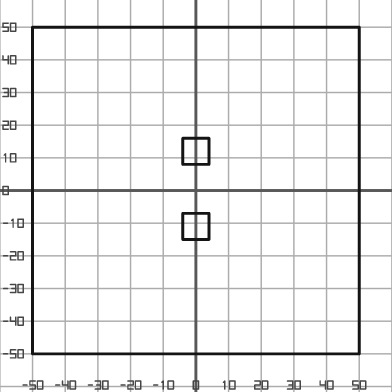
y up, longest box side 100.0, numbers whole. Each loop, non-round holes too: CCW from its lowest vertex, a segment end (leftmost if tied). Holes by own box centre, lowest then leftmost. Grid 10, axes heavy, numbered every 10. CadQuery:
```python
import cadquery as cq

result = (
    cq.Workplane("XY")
    .moveTo(-50.0, -50.0)
    .lineTo(50.0, -50.0)
    .lineTo(50.0, 50.0)
    .lineTo(-50.0, 50.0)
    .close()
    .moveTo(-4.0, -15.0)
    .lineTo(4.0, -15.0)
    .lineTo(4.0, -7.0)
    .lineTo(-4.0, -7.0)
    .close()
    .moveTo(-4.0, 8.0)
    .lineTo(4.0, 8.0)
    .lineTo(4.0, 16.0)
    .lineTo(-4.0, 16.0)
    .close()
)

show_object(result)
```